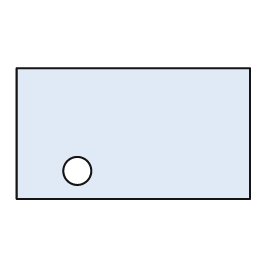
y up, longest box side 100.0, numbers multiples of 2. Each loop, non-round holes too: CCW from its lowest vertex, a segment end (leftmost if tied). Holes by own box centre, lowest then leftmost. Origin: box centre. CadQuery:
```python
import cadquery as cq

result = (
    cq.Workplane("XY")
    .moveTo(-50.0, -28.0)
    .lineTo(50.0, -28.0)
    .lineTo(50.0, 28.0)
    .lineTo(-50.0, 28.0)
    .close()
    .moveTo(-24.0, -16.0)
    .circle(6.0)
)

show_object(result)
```